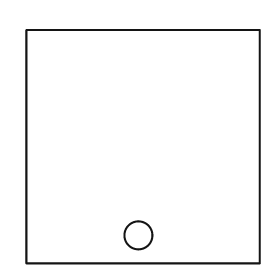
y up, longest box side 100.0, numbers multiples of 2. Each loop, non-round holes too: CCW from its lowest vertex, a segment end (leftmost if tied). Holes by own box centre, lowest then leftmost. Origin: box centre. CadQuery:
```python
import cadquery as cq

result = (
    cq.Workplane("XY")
    .moveTo(-50.0, -50.0)
    .lineTo(50.0, -50.0)
    .lineTo(50.0, 50.0)
    .lineTo(-50.0, 50.0)
    .close()
    .moveTo(-2.0, -38.0)
    .circle(6.0)
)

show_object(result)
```